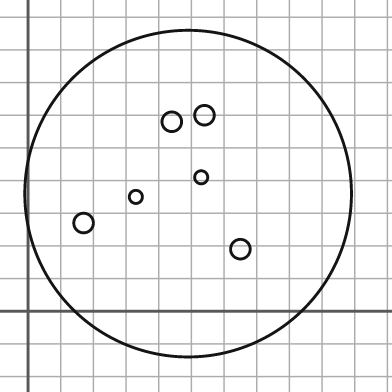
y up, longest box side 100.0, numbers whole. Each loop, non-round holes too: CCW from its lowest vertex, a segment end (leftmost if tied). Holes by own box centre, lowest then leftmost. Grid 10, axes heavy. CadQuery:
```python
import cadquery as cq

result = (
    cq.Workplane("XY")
    .moveTo(49.0, 36.0)
    .circle(50.0)
    .moveTo(65.0, 19.0)
    .circle(3.0)
    .moveTo(17.0, 27.0)
    .circle(3.0)
    .moveTo(33.0, 35.0)
    .circle(2.0)
    .moveTo(53.0, 41.0)
    .circle(2.0)
    .moveTo(44.0, 58.0)
    .circle(3.0)
    .moveTo(54.0, 60.0)
    .circle(3.0)
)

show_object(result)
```